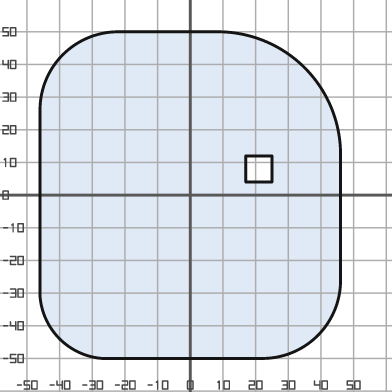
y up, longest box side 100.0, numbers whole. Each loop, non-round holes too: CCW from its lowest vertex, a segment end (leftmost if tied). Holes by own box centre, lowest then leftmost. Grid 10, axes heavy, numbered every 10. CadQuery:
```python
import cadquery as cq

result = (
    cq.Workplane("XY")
    .moveTo(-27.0, -50.0)
    .lineTo(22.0, -50.0)
    .threePointArc((39.0, -43.0), (46.0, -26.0))
    .lineTo(46.0, 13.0)
    .threePointArc((35.0, 39.0), (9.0, 50.0))
    .lineTo(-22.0, 50.0)
    .threePointArc((-39.0, 43.0), (-46.0, 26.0))
    .lineTo(-46.0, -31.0)
    .threePointArc((-40.0, -44.0), (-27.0, -50.0))
    .close()
    .moveTo(17.0, 4.0)
    .lineTo(25.0, 4.0)
    .lineTo(25.0, 12.0)
    .lineTo(17.0, 12.0)
    .close()
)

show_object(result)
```